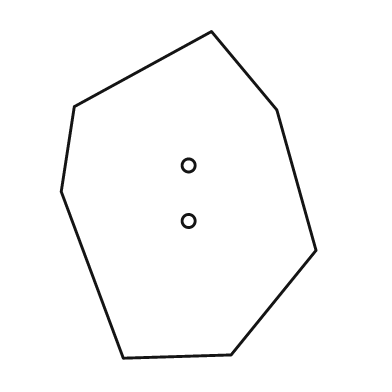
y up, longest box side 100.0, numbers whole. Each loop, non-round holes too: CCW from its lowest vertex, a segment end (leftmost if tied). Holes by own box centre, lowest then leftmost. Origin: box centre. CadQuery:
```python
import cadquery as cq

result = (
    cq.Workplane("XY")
    .moveTo(-20.0, -50.0)
    .lineTo(13.0, -49.0)
    .lineTo(39.0, -17.0)
    .lineTo(27.0, 26.0)
    .lineTo(7.0, 50.0)
    .lineTo(-35.0, 27.0)
    .lineTo(-39.0, 1.0)
    .close()
    .moveTo(0.0, -8.0)
    .circle(2.0)
    .moveTo(0.0, 9.0)
    .circle(2.0)
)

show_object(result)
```